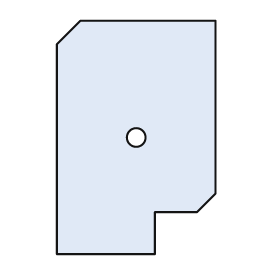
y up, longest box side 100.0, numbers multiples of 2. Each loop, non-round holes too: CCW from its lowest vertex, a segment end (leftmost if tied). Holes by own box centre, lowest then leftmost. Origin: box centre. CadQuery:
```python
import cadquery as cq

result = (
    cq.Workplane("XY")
    .moveTo(-34.0, -50.0)
    .lineTo(8.0, -50.0)
    .lineTo(8.0, -32.0)
    .lineTo(26.0, -32.0)
    .lineTo(34.0, -24.0)
    .lineTo(34.0, 50.0)
    .lineTo(-24.0, 50.0)
    .lineTo(-34.0, 40.0)
    .close()
    .moveTo(0.0, 0.0)
    .circle(4.0)
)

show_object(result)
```